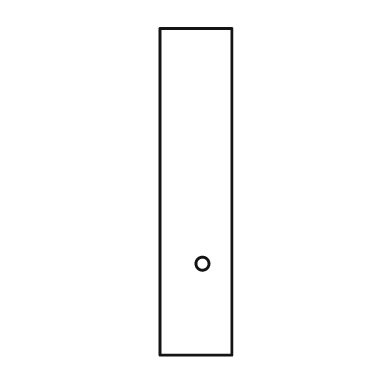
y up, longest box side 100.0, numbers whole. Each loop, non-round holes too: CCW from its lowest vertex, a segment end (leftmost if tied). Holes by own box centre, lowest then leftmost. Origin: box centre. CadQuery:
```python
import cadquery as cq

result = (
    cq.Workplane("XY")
    .moveTo(-11.0, -50.0)
    .lineTo(11.0, -50.0)
    .lineTo(11.0, 50.0)
    .lineTo(-11.0, 50.0)
    .close()
    .moveTo(2.0, -22.0)
    .circle(2.0)
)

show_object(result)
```